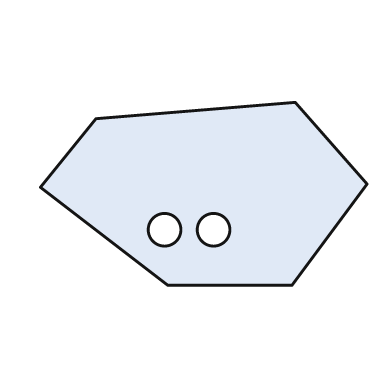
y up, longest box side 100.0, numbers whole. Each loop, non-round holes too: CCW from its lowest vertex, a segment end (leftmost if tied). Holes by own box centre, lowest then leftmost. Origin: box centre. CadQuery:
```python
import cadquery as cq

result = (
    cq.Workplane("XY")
    .moveTo(-11.0, -28.0)
    .lineTo(27.0, -28.0)
    .lineTo(50.0, 3.0)
    .lineTo(28.0, 28.0)
    .lineTo(-33.0, 23.0)
    .lineTo(-50.0, 2.0)
    .close()
    .moveTo(-12.0, -11.0)
    .circle(5.0)
    .moveTo(3.0, -11.0)
    .circle(5.0)
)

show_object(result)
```